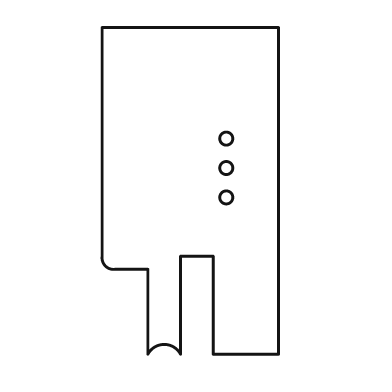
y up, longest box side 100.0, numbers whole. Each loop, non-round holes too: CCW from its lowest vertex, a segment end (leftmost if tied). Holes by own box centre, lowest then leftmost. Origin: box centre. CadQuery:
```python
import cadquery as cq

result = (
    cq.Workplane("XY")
    .moveTo(-13.0, -50.0)
    .threePointArc((-8.0, -47.0), (-3.0, -50.0))
    .lineTo(-3.0, -20.0)
    .lineTo(7.0, -20.0)
    .lineTo(7.0, -50.0)
    .lineTo(27.0, -50.0)
    .lineTo(27.0, 50.0)
    .lineTo(-27.0, 50.0)
    .lineTo(-27.0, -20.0)
    .threePointArc((-26.0, -23.0), (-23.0, -24.0))
    .lineTo(-13.0, -24.0)
    .close()
    .moveTo(11.0, -2.0)
    .circle(2.0)
    .moveTo(11.0, 7.0)
    .circle(2.0)
    .moveTo(11.0, 16.0)
    .circle(2.0)
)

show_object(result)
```